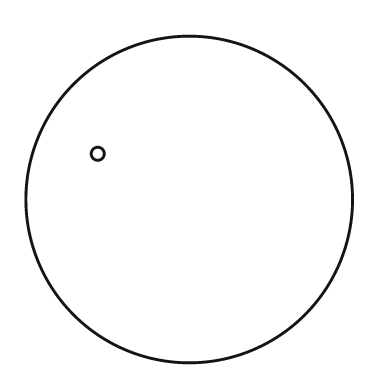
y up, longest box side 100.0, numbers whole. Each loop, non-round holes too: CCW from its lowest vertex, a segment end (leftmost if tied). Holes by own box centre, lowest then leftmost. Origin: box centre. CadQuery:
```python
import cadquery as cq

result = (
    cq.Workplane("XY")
    .moveTo(0.0, 0.0)
    .circle(50.0)
    .moveTo(-28.0, 14.0)
    .circle(2.0)
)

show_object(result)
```